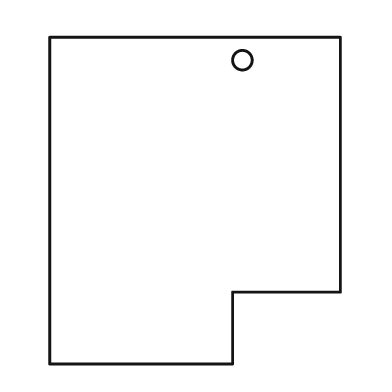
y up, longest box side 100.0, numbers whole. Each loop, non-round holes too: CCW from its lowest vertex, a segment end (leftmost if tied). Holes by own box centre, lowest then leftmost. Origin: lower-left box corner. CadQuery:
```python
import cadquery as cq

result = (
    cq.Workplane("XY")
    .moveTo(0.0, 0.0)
    .lineTo(56.0, 0.0)
    .lineTo(56.0, 22.0)
    .lineTo(89.0, 22.0)
    .lineTo(89.0, 100.0)
    .lineTo(0.0, 100.0)
    .close()
    .moveTo(59.0, 93.0)
    .circle(3.0)
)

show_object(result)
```